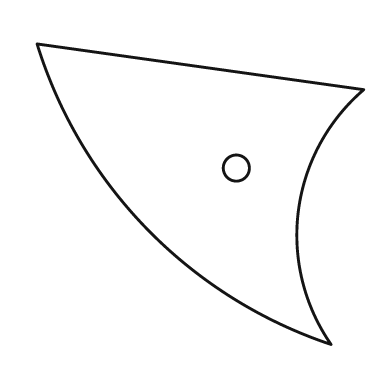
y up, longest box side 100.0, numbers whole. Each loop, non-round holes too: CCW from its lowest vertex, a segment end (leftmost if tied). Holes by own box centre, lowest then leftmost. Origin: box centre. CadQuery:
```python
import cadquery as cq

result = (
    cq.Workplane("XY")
    .moveTo(40.0, -46.0)
    .threePointArc((30.0, -5.0), (50.0, 32.0))
    .lineTo(-50.0, 46.0)
    .threePointArc((-16.0, -11.0), (40.0, -46.0))
    .close()
    .moveTo(11.0, 8.0)
    .circle(4.0)
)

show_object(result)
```